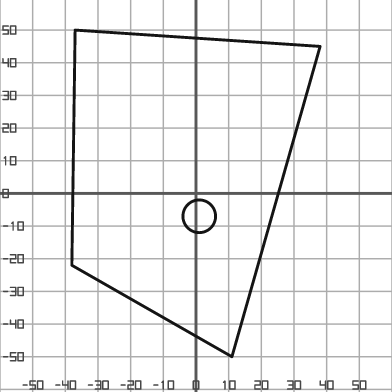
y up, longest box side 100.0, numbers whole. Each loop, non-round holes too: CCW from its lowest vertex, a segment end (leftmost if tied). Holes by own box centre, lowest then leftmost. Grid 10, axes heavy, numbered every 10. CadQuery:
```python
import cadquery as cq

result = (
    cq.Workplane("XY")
    .moveTo(11.0, -50.0)
    .lineTo(38.0, 45.0)
    .lineTo(-37.0, 50.0)
    .lineTo(-38.0, -22.0)
    .close()
    .moveTo(1.0, -7.0)
    .circle(5.0)
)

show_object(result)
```